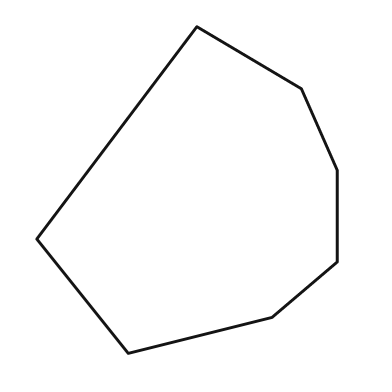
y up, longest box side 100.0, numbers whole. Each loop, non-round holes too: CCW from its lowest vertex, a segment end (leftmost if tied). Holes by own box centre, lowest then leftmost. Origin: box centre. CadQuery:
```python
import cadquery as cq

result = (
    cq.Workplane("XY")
    .moveTo(-18.0, -50.0)
    .lineTo(26.0, -39.0)
    .lineTo(46.0, -22.0)
    .lineTo(46.0, 6.0)
    .lineTo(35.0, 31.0)
    .lineTo(3.0, 50.0)
    .lineTo(-46.0, -15.0)
    .close()
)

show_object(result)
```